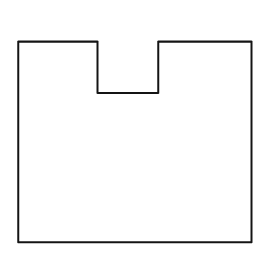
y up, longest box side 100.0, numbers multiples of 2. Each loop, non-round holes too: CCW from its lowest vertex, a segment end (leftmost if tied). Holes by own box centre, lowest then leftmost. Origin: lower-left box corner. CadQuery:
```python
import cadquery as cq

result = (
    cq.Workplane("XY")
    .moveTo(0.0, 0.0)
    .lineTo(100.0, 0.0)
    .lineTo(100.0, 86.0)
    .lineTo(60.0, 86.0)
    .lineTo(60.0, 64.0)
    .lineTo(34.0, 64.0)
    .lineTo(34.0, 86.0)
    .lineTo(0.0, 86.0)
    .close()
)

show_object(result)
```